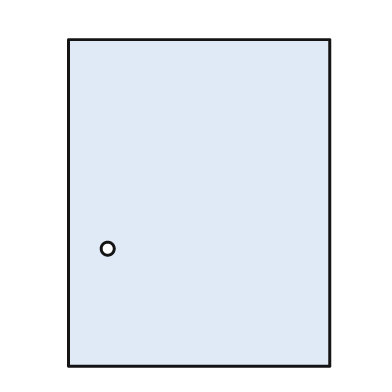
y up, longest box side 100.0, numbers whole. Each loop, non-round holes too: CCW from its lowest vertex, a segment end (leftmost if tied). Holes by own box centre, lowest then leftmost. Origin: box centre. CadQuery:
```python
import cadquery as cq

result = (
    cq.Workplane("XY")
    .moveTo(-40.0, -50.0)
    .lineTo(40.0, -50.0)
    .lineTo(40.0, 50.0)
    .lineTo(-40.0, 50.0)
    .close()
    .moveTo(-28.0, -14.0)
    .circle(2.0)
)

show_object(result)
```